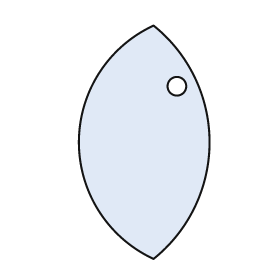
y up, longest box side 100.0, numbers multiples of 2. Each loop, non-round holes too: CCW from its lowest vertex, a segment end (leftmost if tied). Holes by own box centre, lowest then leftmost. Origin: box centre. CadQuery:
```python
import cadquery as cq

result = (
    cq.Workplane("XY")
    .moveTo(4.0, -50.0)
    .threePointArc((28.0, 0.0), (4.0, 50.0))
    .threePointArc((-28.0, 0.0), (4.0, -50.0))
    .close()
    .moveTo(14.0, 24.0)
    .circle(4.0)
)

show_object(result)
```